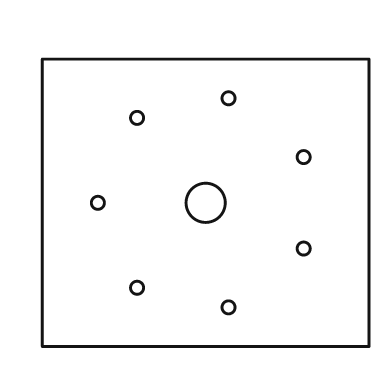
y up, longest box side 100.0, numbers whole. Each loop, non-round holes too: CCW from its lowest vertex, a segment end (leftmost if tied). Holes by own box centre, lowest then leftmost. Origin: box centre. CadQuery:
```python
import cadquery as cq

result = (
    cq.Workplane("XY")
    .moveTo(-50.0, -44.0)
    .lineTo(50.0, -44.0)
    .lineTo(50.0, 44.0)
    .lineTo(-50.0, 44.0)
    .close()
    .moveTo(7.0, -32.0)
    .circle(2.0)
    .moveTo(-21.0, -26.0)
    .circle(2.0)
    .moveTo(30.0, -14.0)
    .circle(2.0)
    .moveTo(-33.0, 0.0)
    .circle(2.0)
    .moveTo(0.0, 0.0)
    .circle(6.0)
    .moveTo(30.0, 14.0)
    .circle(2.0)
    .moveTo(-21.0, 26.0)
    .circle(2.0)
    .moveTo(7.0, 32.0)
    .circle(2.0)
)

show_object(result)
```